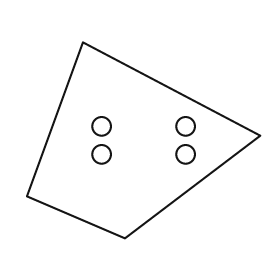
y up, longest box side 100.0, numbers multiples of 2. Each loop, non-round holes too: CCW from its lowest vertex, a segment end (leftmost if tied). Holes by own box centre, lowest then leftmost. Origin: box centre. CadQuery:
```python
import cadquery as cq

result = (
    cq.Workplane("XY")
    .moveTo(-8.0, -42.0)
    .lineTo(50.0, 2.0)
    .lineTo(-26.0, 42.0)
    .lineTo(-50.0, -24.0)
    .close()
    .moveTo(-18.0, -6.0)
    .circle(4.0)
    .moveTo(18.0, -6.0)
    .circle(4.0)
    .moveTo(-18.0, 6.0)
    .circle(4.0)
    .moveTo(18.0, 6.0)
    .circle(4.0)
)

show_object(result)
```